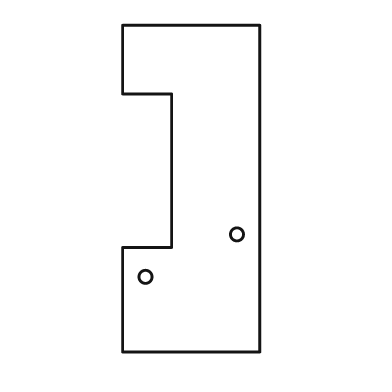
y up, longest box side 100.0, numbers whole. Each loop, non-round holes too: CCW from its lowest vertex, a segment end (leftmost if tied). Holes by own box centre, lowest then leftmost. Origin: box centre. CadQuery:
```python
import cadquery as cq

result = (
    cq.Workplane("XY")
    .moveTo(-21.0, -50.0)
    .lineTo(21.0, -50.0)
    .lineTo(21.0, 50.0)
    .lineTo(-21.0, 50.0)
    .lineTo(-21.0, 29.0)
    .lineTo(-6.0, 29.0)
    .lineTo(-6.0, -18.0)
    .lineTo(-21.0, -18.0)
    .close()
    .moveTo(-14.0, -27.0)
    .circle(2.0)
    .moveTo(14.0, -14.0)
    .circle(2.0)
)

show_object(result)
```